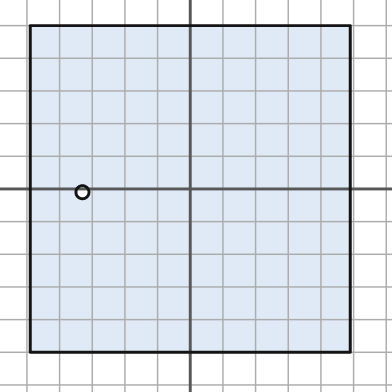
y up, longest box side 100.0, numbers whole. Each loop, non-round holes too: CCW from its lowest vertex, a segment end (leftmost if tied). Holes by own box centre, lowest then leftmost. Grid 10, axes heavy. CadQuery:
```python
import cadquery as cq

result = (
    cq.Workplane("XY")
    .moveTo(-49.0, -50.0)
    .lineTo(49.0, -50.0)
    .lineTo(49.0, 50.0)
    .lineTo(-49.0, 50.0)
    .close()
    .moveTo(-33.0, -1.0)
    .circle(2.0)
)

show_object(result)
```